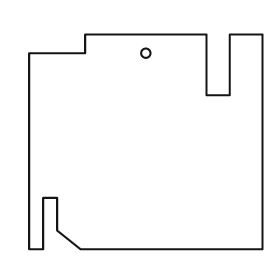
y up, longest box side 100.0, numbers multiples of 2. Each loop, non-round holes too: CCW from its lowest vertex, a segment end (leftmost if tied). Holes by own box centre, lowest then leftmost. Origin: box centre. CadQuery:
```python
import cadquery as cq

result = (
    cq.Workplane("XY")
    .moveTo(-50.0, -46.0)
    .lineTo(-44.0, -46.0)
    .lineTo(-44.0, -24.0)
    .lineTo(-38.0, -24.0)
    .lineTo(-38.0, -38.0)
    .lineTo(-28.0, -46.0)
    .lineTo(50.0, -46.0)
    .lineTo(50.0, 46.0)
    .lineTo(36.0, 46.0)
    .lineTo(36.0, 20.0)
    .lineTo(26.0, 20.0)
    .lineTo(26.0, 46.0)
    .lineTo(-26.0, 46.0)
    .lineTo(-26.0, 38.0)
    .lineTo(-50.0, 38.0)
    .close()
    .moveTo(0.0, 38.0)
    .circle(2.0)
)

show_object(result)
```